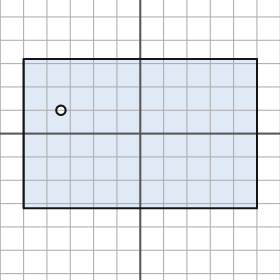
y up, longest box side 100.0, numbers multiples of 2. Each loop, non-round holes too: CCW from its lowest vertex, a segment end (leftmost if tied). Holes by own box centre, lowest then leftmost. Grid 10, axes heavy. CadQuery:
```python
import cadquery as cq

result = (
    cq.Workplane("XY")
    .moveTo(-50.0, -32.0)
    .lineTo(50.0, -32.0)
    .lineTo(50.0, 32.0)
    .lineTo(-50.0, 32.0)
    .close()
    .moveTo(-34.0, 10.0)
    .circle(2.0)
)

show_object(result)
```